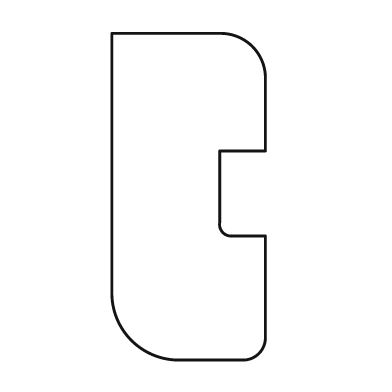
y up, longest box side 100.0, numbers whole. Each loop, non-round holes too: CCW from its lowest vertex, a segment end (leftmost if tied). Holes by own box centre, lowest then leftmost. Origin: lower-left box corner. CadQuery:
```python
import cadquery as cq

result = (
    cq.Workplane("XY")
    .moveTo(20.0, 0.0)
    .lineTo(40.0, 0.0)
    .threePointArc((45.0, 2.0), (47.0, 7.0))
    .lineTo(47.0, 38.0)
    .lineTo(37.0, 38.0)
    .threePointArc((34.0, 39.0), (33.0, 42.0))
    .lineTo(33.0, 64.0)
    .lineTo(47.0, 64.0)
    .lineTo(47.0, 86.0)
    .threePointArc((43.0, 96.0), (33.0, 100.0))
    .lineTo(0.0, 100.0)
    .lineTo(0.0, 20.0)
    .threePointArc((6.0, 6.0), (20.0, 0.0))
    .close()
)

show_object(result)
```